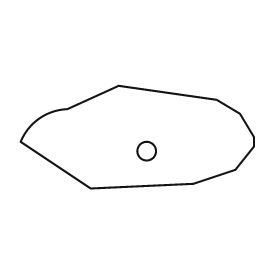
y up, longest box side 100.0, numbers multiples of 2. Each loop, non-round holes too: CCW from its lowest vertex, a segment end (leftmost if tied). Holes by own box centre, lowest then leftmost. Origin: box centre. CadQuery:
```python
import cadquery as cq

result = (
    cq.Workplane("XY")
    .moveTo(-20.0, -22.0)
    .lineTo(24.0, -20.0)
    .lineTo(42.0, -14.0)
    .lineTo(50.0, -4.0)
    .lineTo(50.0, 0.0)
    .lineTo(44.0, 10.0)
    .lineTo(34.0, 16.0)
    .lineTo(-8.0, 22.0)
    .lineTo(-30.0, 12.0)
    .threePointArc((-42.0, 8.0), (-50.0, -2.0))
    .close()
    .moveTo(4.0, -6.0)
    .circle(4.0)
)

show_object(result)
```